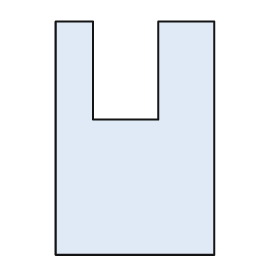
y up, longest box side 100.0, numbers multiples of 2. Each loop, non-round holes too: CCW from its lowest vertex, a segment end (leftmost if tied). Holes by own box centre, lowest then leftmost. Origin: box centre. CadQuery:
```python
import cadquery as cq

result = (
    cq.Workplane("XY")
    .moveTo(-34.0, -50.0)
    .lineTo(34.0, -50.0)
    .lineTo(34.0, 50.0)
    .lineTo(10.0, 50.0)
    .lineTo(10.0, 8.0)
    .lineTo(-18.0, 8.0)
    .lineTo(-18.0, 50.0)
    .lineTo(-34.0, 50.0)
    .close()
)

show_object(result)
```